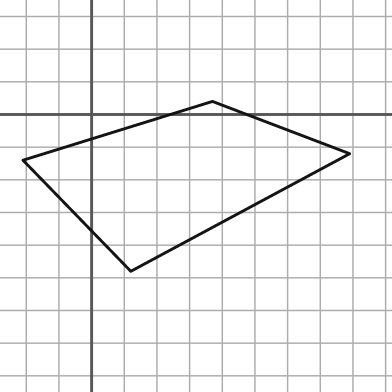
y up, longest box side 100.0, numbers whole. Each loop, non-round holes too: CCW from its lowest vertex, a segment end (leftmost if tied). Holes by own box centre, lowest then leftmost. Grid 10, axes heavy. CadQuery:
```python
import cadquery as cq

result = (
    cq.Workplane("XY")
    .moveTo(12.0, -48.0)
    .lineTo(79.0, -12.0)
    .lineTo(37.0, 4.0)
    .lineTo(-21.0, -14.0)
    .close()
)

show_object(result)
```